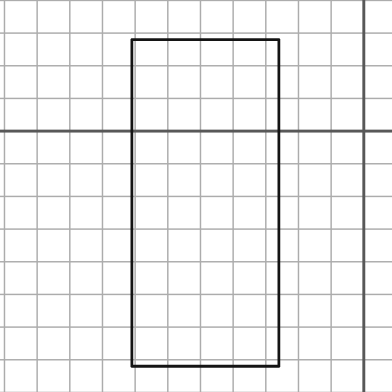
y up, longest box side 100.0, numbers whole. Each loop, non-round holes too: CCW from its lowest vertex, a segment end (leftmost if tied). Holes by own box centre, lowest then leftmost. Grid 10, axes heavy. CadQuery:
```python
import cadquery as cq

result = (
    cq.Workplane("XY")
    .moveTo(-71.0, -72.0)
    .lineTo(-26.0, -72.0)
    .lineTo(-26.0, 28.0)
    .lineTo(-71.0, 28.0)
    .close()
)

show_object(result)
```